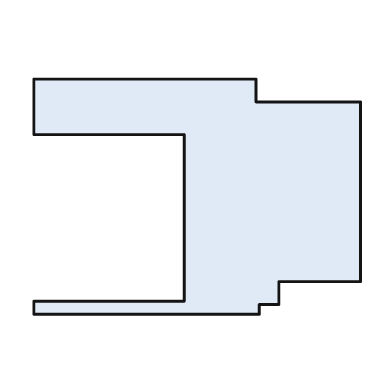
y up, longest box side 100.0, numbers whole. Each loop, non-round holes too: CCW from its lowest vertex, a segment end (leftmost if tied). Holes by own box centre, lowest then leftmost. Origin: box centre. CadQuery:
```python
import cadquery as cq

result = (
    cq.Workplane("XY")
    .moveTo(-50.0, -36.0)
    .lineTo(19.0, -36.0)
    .lineTo(19.0, -33.0)
    .lineTo(25.0, -33.0)
    .lineTo(25.0, -26.0)
    .lineTo(50.0, -26.0)
    .lineTo(50.0, 29.0)
    .lineTo(18.0, 29.0)
    .lineTo(18.0, 36.0)
    .lineTo(-50.0, 36.0)
    .lineTo(-50.0, 19.0)
    .lineTo(-4.0, 19.0)
    .lineTo(-4.0, -32.0)
    .lineTo(-50.0, -32.0)
    .close()
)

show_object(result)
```